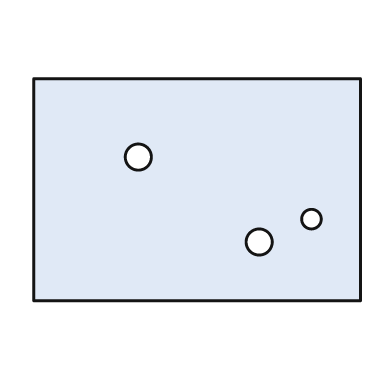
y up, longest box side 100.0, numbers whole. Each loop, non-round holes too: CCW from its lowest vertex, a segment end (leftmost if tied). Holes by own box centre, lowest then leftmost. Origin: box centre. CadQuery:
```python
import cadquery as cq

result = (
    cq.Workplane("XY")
    .moveTo(-50.0, -34.0)
    .lineTo(50.0, -34.0)
    .lineTo(50.0, 34.0)
    .lineTo(-50.0, 34.0)
    .close()
    .moveTo(19.0, -16.0)
    .circle(4.0)
    .moveTo(35.0, -9.0)
    .circle(3.0)
    .moveTo(-18.0, 10.0)
    .circle(4.0)
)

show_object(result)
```